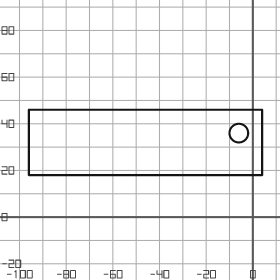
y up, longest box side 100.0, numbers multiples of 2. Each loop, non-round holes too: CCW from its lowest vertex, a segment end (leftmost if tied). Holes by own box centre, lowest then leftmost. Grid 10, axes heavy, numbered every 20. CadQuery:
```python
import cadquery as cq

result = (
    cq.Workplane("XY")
    .moveTo(-96.0, 18.0)
    .lineTo(4.0, 18.0)
    .lineTo(4.0, 46.0)
    .lineTo(-96.0, 46.0)
    .close()
    .moveTo(-6.0, 36.0)
    .circle(4.0)
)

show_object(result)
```